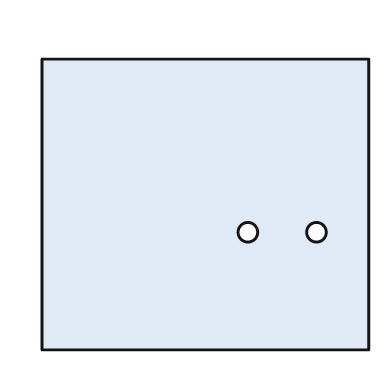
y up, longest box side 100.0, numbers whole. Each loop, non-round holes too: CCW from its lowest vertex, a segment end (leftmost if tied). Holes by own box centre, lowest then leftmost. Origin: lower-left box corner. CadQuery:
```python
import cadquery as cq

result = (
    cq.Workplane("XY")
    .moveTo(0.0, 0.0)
    .lineTo(100.0, 0.0)
    .lineTo(100.0, 89.0)
    .lineTo(0.0, 89.0)
    .close()
    .moveTo(63.0, 36.0)
    .circle(3.0)
    .moveTo(84.0, 36.0)
    .circle(3.0)
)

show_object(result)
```